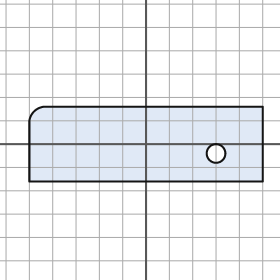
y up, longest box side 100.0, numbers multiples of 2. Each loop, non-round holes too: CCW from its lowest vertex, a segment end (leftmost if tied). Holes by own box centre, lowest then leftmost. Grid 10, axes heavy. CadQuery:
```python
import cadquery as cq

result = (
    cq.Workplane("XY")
    .moveTo(-50.0, -16.0)
    .lineTo(50.0, -16.0)
    .lineTo(50.0, 16.0)
    .lineTo(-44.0, 16.0)
    .threePointArc((-48.0, 14.0), (-50.0, 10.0))
    .close()
    .moveTo(30.0, -4.0)
    .circle(4.0)
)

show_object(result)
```